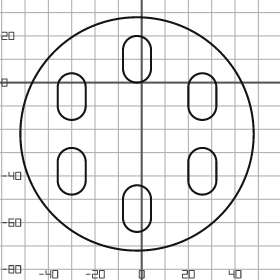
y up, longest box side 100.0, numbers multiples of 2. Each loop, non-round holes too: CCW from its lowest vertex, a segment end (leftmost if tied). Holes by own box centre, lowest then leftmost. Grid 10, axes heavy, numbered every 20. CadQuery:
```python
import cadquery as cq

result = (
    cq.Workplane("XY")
    .moveTo(-2.0, -22.0)
    .circle(50.0)
    .moveTo(-8.0, -58.0)
    .threePointArc((-2.0, -64.0), (4.0, -58.0))
    .lineTo(4.0, -50.0)
    .threePointArc((-2.0, -44.0), (-8.0, -50.0))
    .close()
    .moveTo(-36.0, -42.0)
    .threePointArc((-30.0, -48.0), (-24.0, -42.0))
    .lineTo(-24.0, -34.0)
    .threePointArc((-30.0, -28.0), (-36.0, -34.0))
    .close()
    .moveTo(20.0, -42.0)
    .threePointArc((26.0, -48.0), (32.0, -42.0))
    .lineTo(32.0, -34.0)
    .threePointArc((26.0, -28.0), (20.0, -34.0))
    .close()
    .moveTo(-36.0, -10.0)
    .threePointArc((-30.0, -16.0), (-24.0, -10.0))
    .lineTo(-24.0, -2.0)
    .threePointArc((-30.0, 4.0), (-36.0, -2.0))
    .close()
    .moveTo(20.0, -10.0)
    .threePointArc((26.0, -16.0), (32.0, -10.0))
    .lineTo(32.0, -2.0)
    .threePointArc((26.0, 4.0), (20.0, -2.0))
    .close()
    .moveTo(-8.0, 6.0)
    .threePointArc((-2.0, 0.0), (4.0, 6.0))
    .lineTo(4.0, 14.0)
    .threePointArc((-2.0, 20.0), (-8.0, 14.0))
    .close()
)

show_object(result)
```